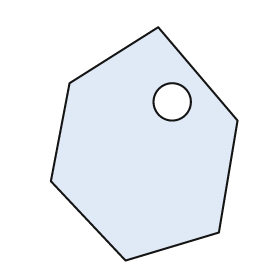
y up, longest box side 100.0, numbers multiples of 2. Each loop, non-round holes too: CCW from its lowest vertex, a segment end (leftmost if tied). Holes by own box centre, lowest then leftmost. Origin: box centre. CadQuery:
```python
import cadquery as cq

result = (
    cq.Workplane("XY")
    .moveTo(-8.0, -50.0)
    .lineTo(32.0, -38.0)
    .lineTo(40.0, 10.0)
    .lineTo(6.0, 50.0)
    .lineTo(-32.0, 26.0)
    .lineTo(-40.0, -16.0)
    .close()
    .moveTo(12.0, 18.0)
    .circle(8.0)
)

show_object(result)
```